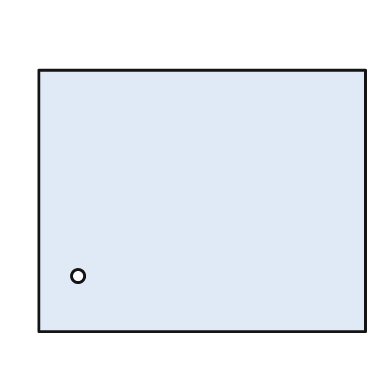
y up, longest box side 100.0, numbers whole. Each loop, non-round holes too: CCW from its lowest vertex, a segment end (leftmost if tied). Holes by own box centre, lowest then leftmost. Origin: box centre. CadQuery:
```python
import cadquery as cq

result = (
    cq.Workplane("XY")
    .moveTo(-50.0, -40.0)
    .lineTo(50.0, -40.0)
    .lineTo(50.0, 40.0)
    .lineTo(-50.0, 40.0)
    .close()
    .moveTo(-38.0, -23.0)
    .circle(2.0)
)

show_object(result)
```